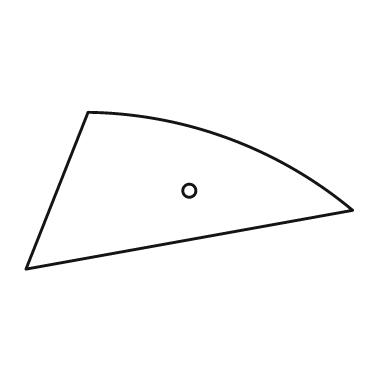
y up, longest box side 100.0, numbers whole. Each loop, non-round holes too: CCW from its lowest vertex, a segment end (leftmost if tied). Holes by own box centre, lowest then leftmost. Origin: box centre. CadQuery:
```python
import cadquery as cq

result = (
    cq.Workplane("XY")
    .moveTo(-50.0, -24.0)
    .lineTo(50.0, -6.0)
    .threePointArc((12.0, 16.0), (-31.0, 24.0))
    .close()
    .moveTo(0.0, 0.0)
    .circle(2.0)
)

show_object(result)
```